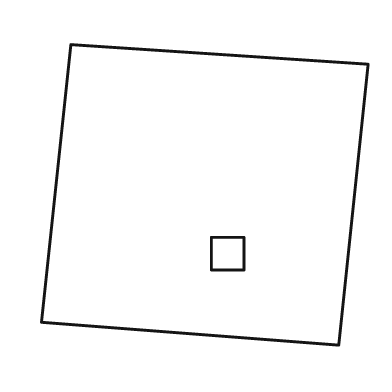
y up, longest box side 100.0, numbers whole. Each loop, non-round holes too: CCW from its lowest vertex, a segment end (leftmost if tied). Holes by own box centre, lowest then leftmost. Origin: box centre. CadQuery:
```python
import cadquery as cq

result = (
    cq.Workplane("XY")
    .moveTo(41.0, -46.0)
    .lineTo(50.0, 40.0)
    .lineTo(-41.0, 46.0)
    .lineTo(-50.0, -39.0)
    .close()
    .moveTo(2.0, -23.0)
    .lineTo(12.0, -23.0)
    .lineTo(12.0, -13.0)
    .lineTo(2.0, -13.0)
    .close()
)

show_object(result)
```